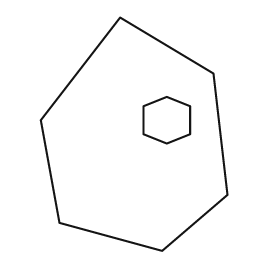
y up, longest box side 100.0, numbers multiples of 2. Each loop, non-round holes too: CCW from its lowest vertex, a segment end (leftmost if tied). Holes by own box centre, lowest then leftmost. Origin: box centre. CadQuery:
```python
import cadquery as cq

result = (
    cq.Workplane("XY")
    .moveTo(12.0, -50.0)
    .lineTo(40.0, -26.0)
    .lineTo(34.0, 26.0)
    .lineTo(-6.0, 50.0)
    .lineTo(-40.0, 6.0)
    .lineTo(-32.0, -38.0)
    .close()
    .moveTo(14.0, -4.0)
    .lineTo(24.0, 0.0)
    .lineTo(24.0, 12.0)
    .lineTo(14.0, 16.0)
    .lineTo(4.0, 12.0)
    .lineTo(4.0, 0.0)
    .close()
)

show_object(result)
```